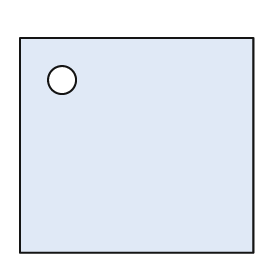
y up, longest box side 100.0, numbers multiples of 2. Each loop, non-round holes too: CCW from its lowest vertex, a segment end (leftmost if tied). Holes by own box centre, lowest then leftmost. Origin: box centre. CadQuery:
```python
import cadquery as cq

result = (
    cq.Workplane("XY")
    .moveTo(-50.0, -46.0)
    .lineTo(50.0, -46.0)
    .lineTo(50.0, 46.0)
    .lineTo(-50.0, 46.0)
    .close()
    .moveTo(-32.0, 28.0)
    .circle(6.0)
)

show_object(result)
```